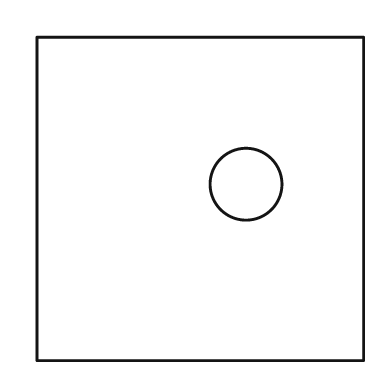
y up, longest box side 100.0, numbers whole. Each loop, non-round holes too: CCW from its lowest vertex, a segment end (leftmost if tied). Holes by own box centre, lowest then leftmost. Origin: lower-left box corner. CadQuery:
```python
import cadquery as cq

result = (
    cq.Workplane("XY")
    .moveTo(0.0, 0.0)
    .lineTo(100.0, 0.0)
    .lineTo(100.0, 99.0)
    .lineTo(0.0, 99.0)
    .close()
    .moveTo(64.0, 54.0)
    .circle(11.0)
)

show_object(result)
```